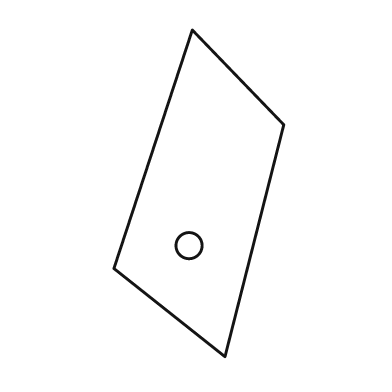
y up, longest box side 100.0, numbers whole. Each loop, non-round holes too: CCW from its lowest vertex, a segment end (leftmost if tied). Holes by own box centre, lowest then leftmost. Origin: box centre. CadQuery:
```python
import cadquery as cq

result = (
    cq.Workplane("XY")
    .moveTo(8.0, -50.0)
    .lineTo(26.0, 21.0)
    .lineTo(-2.0, 50.0)
    .lineTo(-26.0, -23.0)
    .close()
    .moveTo(-3.0, -16.0)
    .circle(4.0)
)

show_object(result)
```